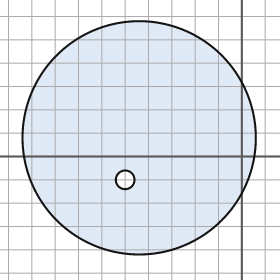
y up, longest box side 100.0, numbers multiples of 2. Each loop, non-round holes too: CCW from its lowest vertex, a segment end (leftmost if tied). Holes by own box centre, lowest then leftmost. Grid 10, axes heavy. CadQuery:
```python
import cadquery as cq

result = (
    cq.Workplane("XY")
    .moveTo(-44.0, 8.0)
    .circle(50.0)
    .moveTo(-50.0, -10.0)
    .circle(4.0)
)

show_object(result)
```